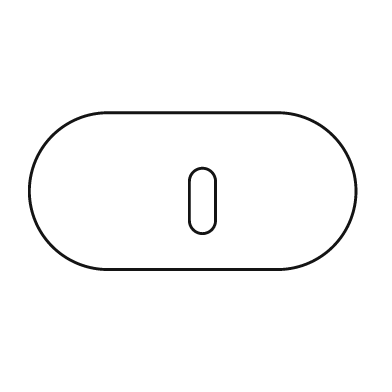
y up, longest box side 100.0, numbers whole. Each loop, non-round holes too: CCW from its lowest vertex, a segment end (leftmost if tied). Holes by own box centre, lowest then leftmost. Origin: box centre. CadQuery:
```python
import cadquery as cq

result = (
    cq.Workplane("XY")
    .moveTo(-26.0, -24.0)
    .lineTo(26.0, -24.0)
    .threePointArc((50.0, 0.0), (26.0, 24.0))
    .lineTo(-26.0, 24.0)
    .threePointArc((-50.0, 0.0), (-26.0, -24.0))
    .close()
    .moveTo(-1.0, -9.0)
    .threePointArc((3.0, -13.0), (7.0, -9.0))
    .lineTo(7.0, 3.0)
    .threePointArc((3.0, 7.0), (-1.0, 3.0))
    .close()
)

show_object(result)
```